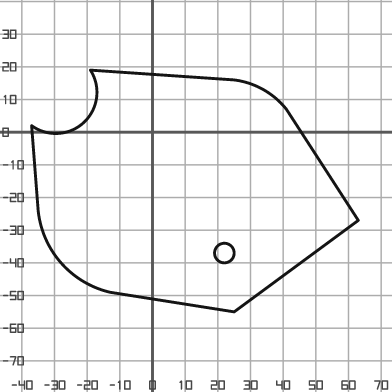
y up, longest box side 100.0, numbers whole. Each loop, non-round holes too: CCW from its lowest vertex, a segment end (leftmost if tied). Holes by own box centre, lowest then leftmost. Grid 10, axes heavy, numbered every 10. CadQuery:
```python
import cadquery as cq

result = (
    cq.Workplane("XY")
    .moveTo(25.0, -55.0)
    .lineTo(63.0, -27.0)
    .lineTo(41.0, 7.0)
    .threePointArc((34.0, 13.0), (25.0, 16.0))
    .lineTo(-19.0, 19.0)
    .threePointArc((-21.0, 3.0), (-37.0, 2.0))
    .lineTo(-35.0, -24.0)
    .threePointArc((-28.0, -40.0), (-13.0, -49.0))
    .close()
    .moveTo(22.0, -37.0)
    .circle(3.0)
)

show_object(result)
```